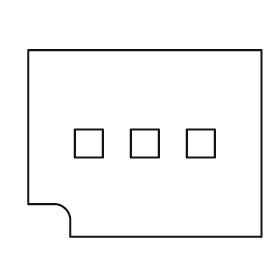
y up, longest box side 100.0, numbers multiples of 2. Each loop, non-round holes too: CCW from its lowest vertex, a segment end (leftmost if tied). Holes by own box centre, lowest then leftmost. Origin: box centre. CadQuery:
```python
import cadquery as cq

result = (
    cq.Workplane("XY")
    .moveTo(-32.0, -40.0)
    .lineTo(50.0, -40.0)
    .lineTo(50.0, 40.0)
    .lineTo(-50.0, 40.0)
    .lineTo(-50.0, -26.0)
    .lineTo(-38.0, -26.0)
    .threePointArc((-34.0, -28.0), (-32.0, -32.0))
    .close()
    .moveTo(-30.0, -6.0)
    .lineTo(-18.0, -6.0)
    .lineTo(-18.0, 6.0)
    .lineTo(-30.0, 6.0)
    .close()
    .moveTo(-6.0, -6.0)
    .lineTo(6.0, -6.0)
    .lineTo(6.0, 6.0)
    .lineTo(-6.0, 6.0)
    .close()
    .moveTo(18.0, -6.0)
    .lineTo(30.0, -6.0)
    .lineTo(30.0, 6.0)
    .lineTo(18.0, 6.0)
    .close()
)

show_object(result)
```